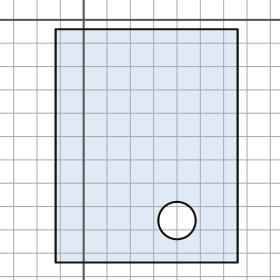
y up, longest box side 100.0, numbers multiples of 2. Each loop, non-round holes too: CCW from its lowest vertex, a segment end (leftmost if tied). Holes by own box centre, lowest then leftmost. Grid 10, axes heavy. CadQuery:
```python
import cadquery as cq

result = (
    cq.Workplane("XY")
    .moveTo(-12.0, -104.0)
    .lineTo(66.0, -104.0)
    .lineTo(66.0, -4.0)
    .lineTo(-12.0, -4.0)
    .close()
    .moveTo(40.0, -86.0)
    .circle(8.0)
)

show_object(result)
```